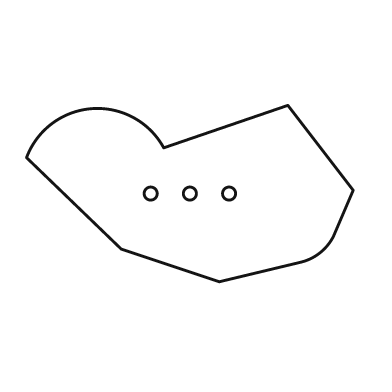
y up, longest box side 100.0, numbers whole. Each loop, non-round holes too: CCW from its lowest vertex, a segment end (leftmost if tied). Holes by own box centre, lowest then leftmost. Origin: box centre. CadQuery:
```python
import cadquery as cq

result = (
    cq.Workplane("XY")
    .moveTo(9.0, -27.0)
    .lineTo(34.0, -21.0)
    .threePointArc((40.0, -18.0), (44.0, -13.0))
    .lineTo(50.0, 1.0)
    .lineTo(30.0, 27.0)
    .lineTo(-8.0, 14.0)
    .threePointArc((-30.0, 26.0), (-50.0, 11.0))
    .lineTo(-21.0, -17.0)
    .close()
    .moveTo(-12.0, 0.0)
    .circle(2.0)
    .moveTo(0.0, 0.0)
    .circle(2.0)
    .moveTo(12.0, 0.0)
    .circle(2.0)
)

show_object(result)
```